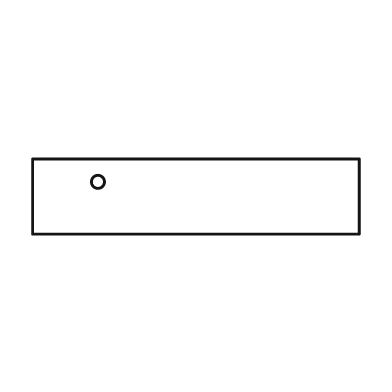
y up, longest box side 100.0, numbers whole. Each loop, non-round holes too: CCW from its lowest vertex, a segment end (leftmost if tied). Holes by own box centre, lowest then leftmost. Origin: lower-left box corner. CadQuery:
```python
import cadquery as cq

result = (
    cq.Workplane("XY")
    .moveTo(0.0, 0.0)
    .lineTo(100.0, 0.0)
    .lineTo(100.0, 23.0)
    .lineTo(0.0, 23.0)
    .close()
    .moveTo(20.0, 16.0)
    .circle(2.0)
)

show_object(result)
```